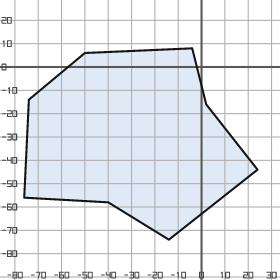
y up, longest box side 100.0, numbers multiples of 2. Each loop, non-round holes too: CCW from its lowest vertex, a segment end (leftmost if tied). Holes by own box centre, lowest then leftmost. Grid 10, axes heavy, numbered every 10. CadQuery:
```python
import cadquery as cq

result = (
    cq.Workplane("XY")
    .moveTo(-14.0, -74.0)
    .lineTo(24.0, -44.0)
    .lineTo(2.0, -16.0)
    .lineTo(-4.0, 8.0)
    .lineTo(-50.0, 6.0)
    .lineTo(-74.0, -14.0)
    .lineTo(-76.0, -56.0)
    .lineTo(-40.0, -58.0)
    .close()
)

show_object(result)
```